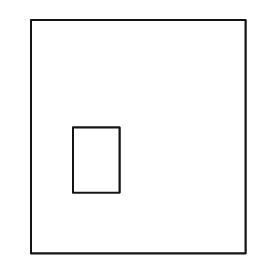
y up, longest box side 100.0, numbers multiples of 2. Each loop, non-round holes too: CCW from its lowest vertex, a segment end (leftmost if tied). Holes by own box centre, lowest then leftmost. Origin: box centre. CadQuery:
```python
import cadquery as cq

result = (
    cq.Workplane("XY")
    .moveTo(-46.0, -50.0)
    .lineTo(46.0, -50.0)
    .lineTo(46.0, 50.0)
    .lineTo(-46.0, 50.0)
    .close()
    .moveTo(-28.0, -24.0)
    .lineTo(-8.0, -24.0)
    .lineTo(-8.0, 4.0)
    .lineTo(-28.0, 4.0)
    .close()
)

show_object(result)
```